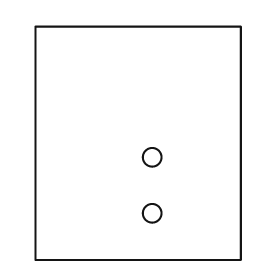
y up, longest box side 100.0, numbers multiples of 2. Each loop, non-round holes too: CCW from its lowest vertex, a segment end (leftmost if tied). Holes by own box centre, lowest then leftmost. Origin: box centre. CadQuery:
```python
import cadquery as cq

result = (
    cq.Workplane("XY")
    .moveTo(-44.0, -50.0)
    .lineTo(44.0, -50.0)
    .lineTo(44.0, 50.0)
    .lineTo(-44.0, 50.0)
    .close()
    .moveTo(6.0, -30.0)
    .circle(4.0)
    .moveTo(6.0, -6.0)
    .circle(4.0)
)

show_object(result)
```